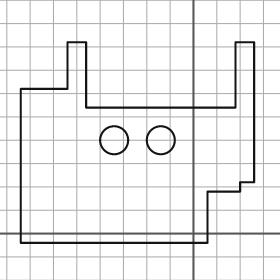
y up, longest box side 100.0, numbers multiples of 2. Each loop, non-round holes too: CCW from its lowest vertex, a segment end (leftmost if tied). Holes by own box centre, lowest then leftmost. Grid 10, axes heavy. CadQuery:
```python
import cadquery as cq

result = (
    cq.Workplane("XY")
    .moveTo(-74.0, -4.0)
    .lineTo(6.0, -4.0)
    .lineTo(6.0, 18.0)
    .lineTo(20.0, 18.0)
    .lineTo(20.0, 22.0)
    .lineTo(26.0, 22.0)
    .lineTo(26.0, 82.0)
    .lineTo(18.0, 82.0)
    .lineTo(18.0, 54.0)
    .lineTo(-46.0, 54.0)
    .lineTo(-46.0, 82.0)
    .lineTo(-54.0, 82.0)
    .lineTo(-54.0, 62.0)
    .lineTo(-74.0, 62.0)
    .close()
    .moveTo(-34.0, 40.0)
    .circle(6.0)
    .moveTo(-14.0, 40.0)
    .circle(6.0)
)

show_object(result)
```